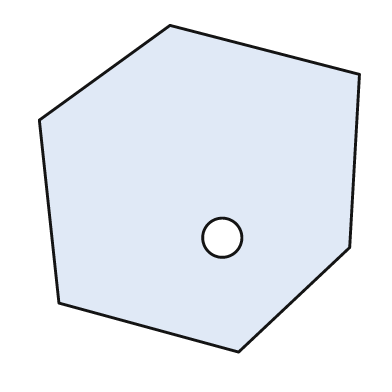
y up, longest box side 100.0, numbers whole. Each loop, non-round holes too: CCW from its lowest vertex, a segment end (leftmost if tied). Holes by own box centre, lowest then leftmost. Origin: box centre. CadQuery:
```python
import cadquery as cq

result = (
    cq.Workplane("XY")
    .moveTo(12.0, -50.0)
    .lineTo(46.0, -18.0)
    .lineTo(49.0, 35.0)
    .lineTo(-9.0, 50.0)
    .lineTo(-49.0, 21.0)
    .lineTo(-43.0, -35.0)
    .close()
    .moveTo(7.0, -15.0)
    .circle(6.0)
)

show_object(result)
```